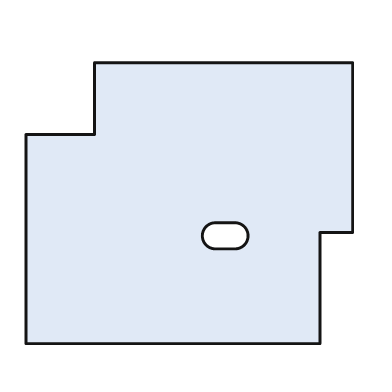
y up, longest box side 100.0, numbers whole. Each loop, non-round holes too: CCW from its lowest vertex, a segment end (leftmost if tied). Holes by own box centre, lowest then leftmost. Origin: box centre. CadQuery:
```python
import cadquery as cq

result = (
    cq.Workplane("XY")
    .moveTo(-50.0, -43.0)
    .lineTo(40.0, -43.0)
    .lineTo(40.0, -9.0)
    .lineTo(50.0, -9.0)
    .lineTo(50.0, 43.0)
    .lineTo(-29.0, 43.0)
    .lineTo(-29.0, 21.0)
    .lineTo(-50.0, 21.0)
    .close()
    .moveTo(8.0, -14.0)
    .lineTo(14.0, -14.0)
    .threePointArc((18.0, -10.0), (14.0, -6.0))
    .lineTo(8.0, -6.0)
    .threePointArc((4.0, -10.0), (8.0, -14.0))
    .close()
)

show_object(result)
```